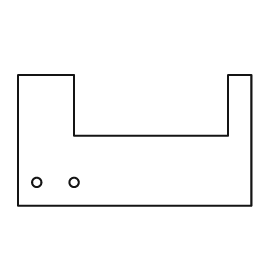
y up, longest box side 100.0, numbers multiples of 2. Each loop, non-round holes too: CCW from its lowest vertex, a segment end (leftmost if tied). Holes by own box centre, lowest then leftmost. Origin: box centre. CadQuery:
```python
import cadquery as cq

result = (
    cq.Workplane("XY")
    .moveTo(-50.0, -28.0)
    .lineTo(50.0, -28.0)
    .lineTo(50.0, 28.0)
    .lineTo(40.0, 28.0)
    .lineTo(40.0, 2.0)
    .lineTo(-26.0, 2.0)
    .lineTo(-26.0, 28.0)
    .lineTo(-50.0, 28.0)
    .close()
    .moveTo(-42.0, -18.0)
    .circle(2.0)
    .moveTo(-26.0, -18.0)
    .circle(2.0)
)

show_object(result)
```